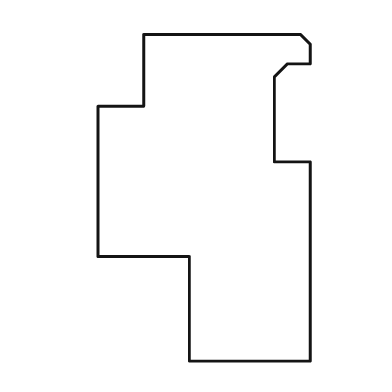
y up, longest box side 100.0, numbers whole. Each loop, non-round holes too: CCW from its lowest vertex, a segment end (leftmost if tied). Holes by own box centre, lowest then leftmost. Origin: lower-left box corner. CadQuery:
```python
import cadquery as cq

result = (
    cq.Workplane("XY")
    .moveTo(28.0, 0.0)
    .lineTo(65.0, 0.0)
    .lineTo(65.0, 61.0)
    .lineTo(54.0, 61.0)
    .lineTo(54.0, 87.0)
    .lineTo(58.0, 91.0)
    .lineTo(65.0, 91.0)
    .lineTo(65.0, 97.0)
    .lineTo(62.0, 100.0)
    .lineTo(14.0, 100.0)
    .lineTo(14.0, 78.0)
    .lineTo(0.0, 78.0)
    .lineTo(0.0, 32.0)
    .lineTo(28.0, 32.0)
    .close()
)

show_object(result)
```